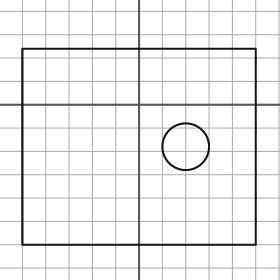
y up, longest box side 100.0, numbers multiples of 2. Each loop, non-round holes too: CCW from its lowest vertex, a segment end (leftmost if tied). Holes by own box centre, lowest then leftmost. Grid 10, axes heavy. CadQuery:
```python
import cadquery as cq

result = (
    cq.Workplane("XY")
    .moveTo(-50.0, -60.0)
    .lineTo(50.0, -60.0)
    .lineTo(50.0, 24.0)
    .lineTo(-50.0, 24.0)
    .close()
    .moveTo(20.0, -18.0)
    .circle(10.0)
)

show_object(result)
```